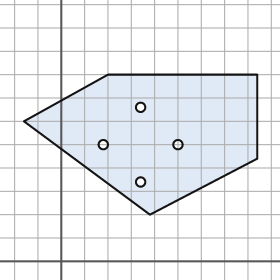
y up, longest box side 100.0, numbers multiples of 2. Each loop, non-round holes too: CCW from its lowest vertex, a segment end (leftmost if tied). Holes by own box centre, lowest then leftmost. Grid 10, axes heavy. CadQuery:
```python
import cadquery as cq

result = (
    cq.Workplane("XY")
    .moveTo(38.0, 20.0)
    .lineTo(84.0, 44.0)
    .lineTo(84.0, 80.0)
    .lineTo(20.0, 80.0)
    .lineTo(-16.0, 60.0)
    .close()
    .moveTo(34.0, 34.0)
    .circle(2.0)
    .moveTo(18.0, 50.0)
    .circle(2.0)
    .moveTo(50.0, 50.0)
    .circle(2.0)
    .moveTo(34.0, 66.0)
    .circle(2.0)
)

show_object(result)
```